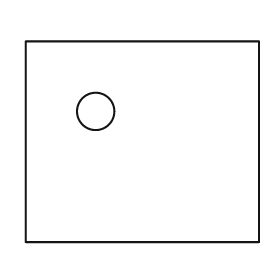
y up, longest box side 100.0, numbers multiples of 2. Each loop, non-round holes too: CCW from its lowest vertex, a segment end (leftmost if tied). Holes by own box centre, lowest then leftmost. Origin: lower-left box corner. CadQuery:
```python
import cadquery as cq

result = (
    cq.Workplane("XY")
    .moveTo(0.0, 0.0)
    .lineTo(100.0, 0.0)
    .lineTo(100.0, 86.0)
    .lineTo(0.0, 86.0)
    .close()
    .moveTo(30.0, 56.0)
    .circle(8.0)
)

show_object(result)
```